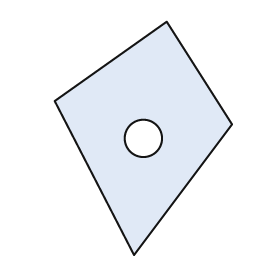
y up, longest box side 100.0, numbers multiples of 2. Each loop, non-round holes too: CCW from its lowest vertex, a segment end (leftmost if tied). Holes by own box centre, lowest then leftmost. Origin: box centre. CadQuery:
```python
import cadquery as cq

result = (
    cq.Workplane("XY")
    .moveTo(-4.0, -50.0)
    .lineTo(38.0, 6.0)
    .lineTo(10.0, 50.0)
    .lineTo(-38.0, 16.0)
    .close()
    .moveTo(0.0, 0.0)
    .circle(8.0)
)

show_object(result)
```